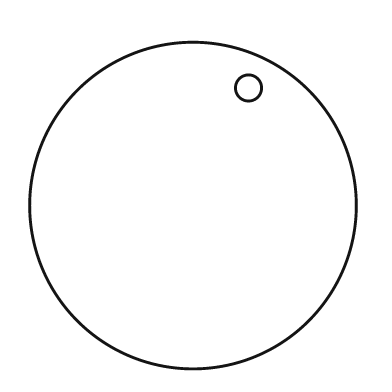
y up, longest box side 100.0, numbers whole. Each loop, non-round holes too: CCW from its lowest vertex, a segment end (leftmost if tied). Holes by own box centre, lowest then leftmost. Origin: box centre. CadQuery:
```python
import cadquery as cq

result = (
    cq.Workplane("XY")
    .moveTo(0.0, 0.0)
    .circle(50.0)
    .moveTo(17.0, 36.0)
    .circle(4.0)
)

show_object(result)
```